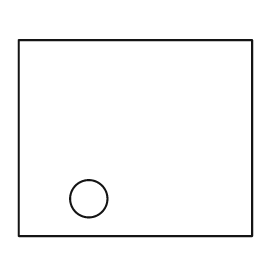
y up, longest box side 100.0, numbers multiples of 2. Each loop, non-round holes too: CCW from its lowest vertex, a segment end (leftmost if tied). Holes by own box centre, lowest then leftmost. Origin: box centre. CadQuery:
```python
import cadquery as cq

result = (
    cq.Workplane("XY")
    .moveTo(-50.0, -42.0)
    .lineTo(50.0, -42.0)
    .lineTo(50.0, 42.0)
    .lineTo(-50.0, 42.0)
    .close()
    .moveTo(-20.0, -26.0)
    .circle(8.0)
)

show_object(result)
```